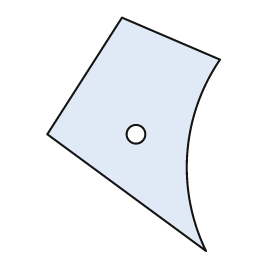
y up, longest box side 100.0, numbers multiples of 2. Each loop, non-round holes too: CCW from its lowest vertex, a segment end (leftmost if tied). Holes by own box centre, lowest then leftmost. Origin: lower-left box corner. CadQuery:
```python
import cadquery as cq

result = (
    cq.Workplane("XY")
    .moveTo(68.0, 0.0)
    .threePointArc((60.0, 42.0), (74.0, 82.0))
    .lineTo(32.0, 100.0)
    .lineTo(0.0, 50.0)
    .close()
    .moveTo(38.0, 50.0)
    .circle(4.0)
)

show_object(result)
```